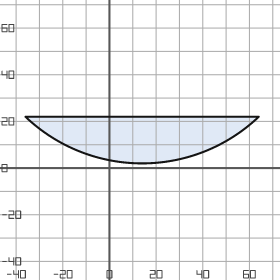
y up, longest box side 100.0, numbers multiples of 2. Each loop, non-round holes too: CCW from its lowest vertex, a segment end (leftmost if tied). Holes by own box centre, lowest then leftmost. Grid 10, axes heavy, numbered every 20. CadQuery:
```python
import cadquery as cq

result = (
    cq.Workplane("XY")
    .moveTo(-36.0, 22.0)
    .threePointArc((14.0, 2.0), (64.0, 22.0))
    .close()
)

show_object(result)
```